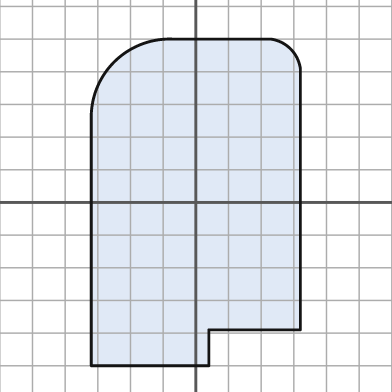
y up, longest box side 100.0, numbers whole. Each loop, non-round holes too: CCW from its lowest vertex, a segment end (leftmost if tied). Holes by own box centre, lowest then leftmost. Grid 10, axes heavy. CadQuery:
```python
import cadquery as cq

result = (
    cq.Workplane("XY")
    .moveTo(-32.0, -50.0)
    .lineTo(4.0, -50.0)
    .lineTo(4.0, -39.0)
    .lineTo(32.0, -39.0)
    .lineTo(32.0, 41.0)
    .threePointArc((29.0, 47.0), (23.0, 50.0))
    .lineTo(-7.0, 50.0)
    .threePointArc((-25.0, 43.0), (-32.0, 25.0))
    .close()
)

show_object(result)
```